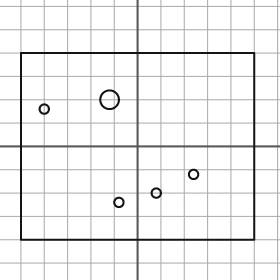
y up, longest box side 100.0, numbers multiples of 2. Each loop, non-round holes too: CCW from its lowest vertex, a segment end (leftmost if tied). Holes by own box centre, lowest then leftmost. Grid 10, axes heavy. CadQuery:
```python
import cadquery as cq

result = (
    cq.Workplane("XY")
    .moveTo(-50.0, -40.0)
    .lineTo(50.0, -40.0)
    .lineTo(50.0, 40.0)
    .lineTo(-50.0, 40.0)
    .close()
    .moveTo(-8.0, -24.0)
    .circle(2.0)
    .moveTo(8.0, -20.0)
    .circle(2.0)
    .moveTo(24.0, -12.0)
    .circle(2.0)
    .moveTo(-40.0, 16.0)
    .circle(2.0)
    .moveTo(-12.0, 20.0)
    .circle(4.0)
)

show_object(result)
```